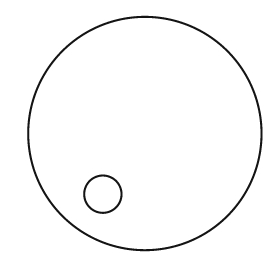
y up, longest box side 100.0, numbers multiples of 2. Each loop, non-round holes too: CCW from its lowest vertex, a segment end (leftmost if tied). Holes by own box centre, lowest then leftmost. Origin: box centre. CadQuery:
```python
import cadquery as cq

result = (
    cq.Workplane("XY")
    .moveTo(0.0, 0.0)
    .circle(50.0)
    .moveTo(-18.0, -26.0)
    .circle(8.0)
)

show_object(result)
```